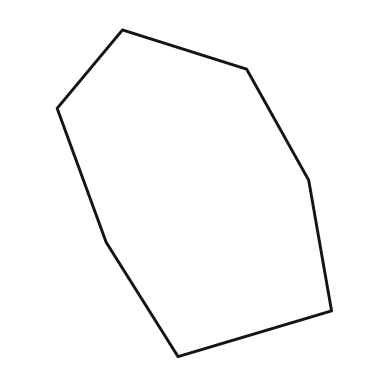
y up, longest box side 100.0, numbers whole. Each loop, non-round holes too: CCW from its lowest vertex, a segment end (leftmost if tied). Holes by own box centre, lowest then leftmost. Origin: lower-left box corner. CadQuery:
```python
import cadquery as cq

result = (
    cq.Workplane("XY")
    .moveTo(37.0, 0.0)
    .lineTo(84.0, 14.0)
    .lineTo(77.0, 54.0)
    .lineTo(58.0, 88.0)
    .lineTo(20.0, 100.0)
    .lineTo(0.0, 76.0)
    .lineTo(15.0, 35.0)
    .close()
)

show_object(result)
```